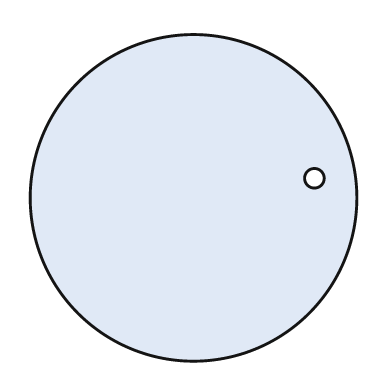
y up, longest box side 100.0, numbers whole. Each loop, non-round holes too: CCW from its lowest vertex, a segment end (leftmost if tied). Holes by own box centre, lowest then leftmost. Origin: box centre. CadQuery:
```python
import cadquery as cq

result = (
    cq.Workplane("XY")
    .moveTo(0.0, 0.0)
    .circle(50.0)
    .moveTo(37.0, 6.0)
    .circle(3.0)
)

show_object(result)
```